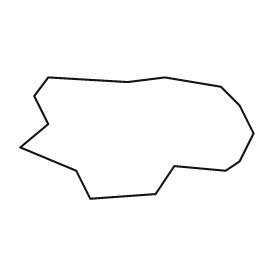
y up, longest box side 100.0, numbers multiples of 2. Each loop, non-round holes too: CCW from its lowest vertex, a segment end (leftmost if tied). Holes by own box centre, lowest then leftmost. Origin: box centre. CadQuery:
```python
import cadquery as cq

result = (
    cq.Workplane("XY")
    .moveTo(-20.0, -26.0)
    .lineTo(8.0, -24.0)
    .lineTo(16.0, -12.0)
    .lineTo(38.0, -14.0)
    .lineTo(44.0, -10.0)
    .lineTo(50.0, 2.0)
    .lineTo(44.0, 14.0)
    .lineTo(36.0, 22.0)
    .lineTo(12.0, 26.0)
    .lineTo(-4.0, 24.0)
    .lineTo(-38.0, 26.0)
    .lineTo(-44.0, 18.0)
    .lineTo(-38.0, 6.0)
    .lineTo(-50.0, -4.0)
    .lineTo(-26.0, -14.0)
    .close()
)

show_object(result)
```